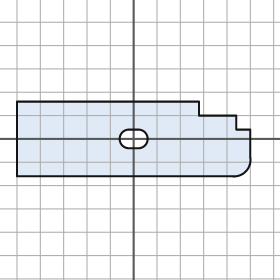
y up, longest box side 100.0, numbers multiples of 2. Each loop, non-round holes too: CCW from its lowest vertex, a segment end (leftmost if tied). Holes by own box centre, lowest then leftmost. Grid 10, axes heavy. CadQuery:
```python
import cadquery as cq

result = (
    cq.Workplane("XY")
    .moveTo(-50.0, -16.0)
    .lineTo(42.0, -16.0)
    .threePointArc((48.0, -14.0), (50.0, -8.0))
    .lineTo(50.0, 4.0)
    .lineTo(44.0, 4.0)
    .lineTo(44.0, 10.0)
    .lineTo(28.0, 10.0)
    .lineTo(28.0, 16.0)
    .lineTo(-50.0, 16.0)
    .close()
    .moveTo(-2.0, -4.0)
    .lineTo(2.0, -4.0)
    .threePointArc((6.0, 0.0), (2.0, 4.0))
    .lineTo(-2.0, 4.0)
    .threePointArc((-6.0, 0.0), (-2.0, -4.0))
    .close()
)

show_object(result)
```